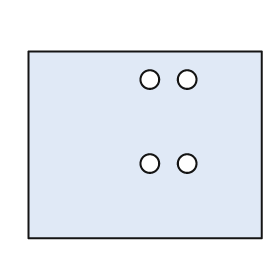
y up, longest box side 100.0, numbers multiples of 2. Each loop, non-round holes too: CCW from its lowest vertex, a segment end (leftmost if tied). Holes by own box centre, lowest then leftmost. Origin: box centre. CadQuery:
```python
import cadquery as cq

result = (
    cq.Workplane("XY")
    .moveTo(-50.0, -40.0)
    .lineTo(50.0, -40.0)
    .lineTo(50.0, 40.0)
    .lineTo(-50.0, 40.0)
    .close()
    .moveTo(2.0, -8.0)
    .circle(4.0)
    .moveTo(18.0, -8.0)
    .circle(4.0)
    .moveTo(2.0, 28.0)
    .circle(4.0)
    .moveTo(18.0, 28.0)
    .circle(4.0)
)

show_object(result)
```